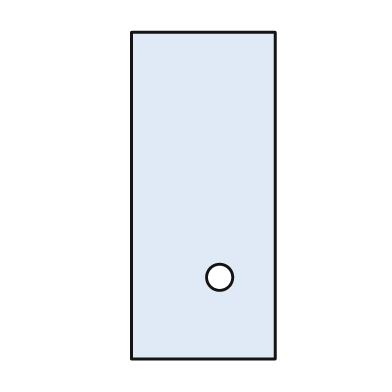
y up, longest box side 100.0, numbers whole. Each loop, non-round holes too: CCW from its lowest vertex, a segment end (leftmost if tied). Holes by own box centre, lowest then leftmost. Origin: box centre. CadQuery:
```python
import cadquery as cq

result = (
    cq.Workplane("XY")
    .moveTo(-22.0, -50.0)
    .lineTo(22.0, -50.0)
    .lineTo(22.0, 50.0)
    .lineTo(-22.0, 50.0)
    .close()
    .moveTo(5.0, -25.0)
    .circle(4.0)
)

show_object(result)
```